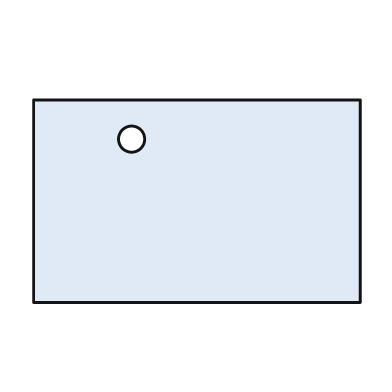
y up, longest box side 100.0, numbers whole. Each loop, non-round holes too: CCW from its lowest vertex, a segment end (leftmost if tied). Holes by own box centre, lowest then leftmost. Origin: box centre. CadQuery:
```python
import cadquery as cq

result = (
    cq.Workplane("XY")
    .moveTo(-50.0, -31.0)
    .lineTo(50.0, -31.0)
    .lineTo(50.0, 31.0)
    .lineTo(-50.0, 31.0)
    .close()
    .moveTo(-20.0, 19.0)
    .circle(4.0)
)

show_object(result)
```